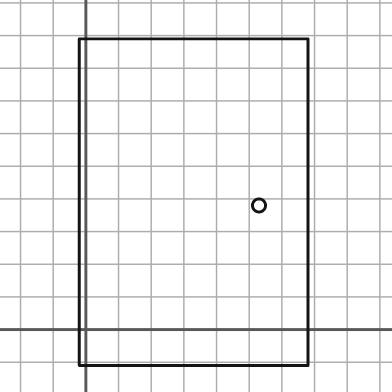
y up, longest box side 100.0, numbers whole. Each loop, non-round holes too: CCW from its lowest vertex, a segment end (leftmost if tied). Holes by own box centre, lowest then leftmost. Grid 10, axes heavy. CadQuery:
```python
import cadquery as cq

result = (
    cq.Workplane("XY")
    .moveTo(-2.0, -11.0)
    .lineTo(68.0, -11.0)
    .lineTo(68.0, 89.0)
    .lineTo(-2.0, 89.0)
    .close()
    .moveTo(53.0, 38.0)
    .circle(2.0)
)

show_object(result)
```